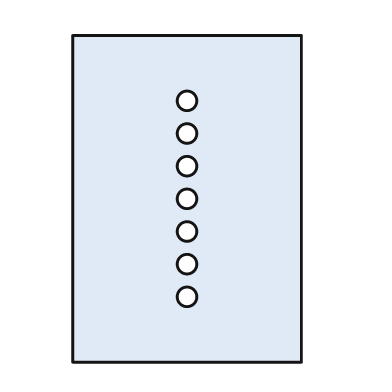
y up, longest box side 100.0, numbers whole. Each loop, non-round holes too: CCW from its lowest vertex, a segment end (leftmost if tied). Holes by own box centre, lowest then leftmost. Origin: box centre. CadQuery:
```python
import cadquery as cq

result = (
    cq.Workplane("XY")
    .moveTo(-35.0, -50.0)
    .lineTo(35.0, -50.0)
    .lineTo(35.0, 50.0)
    .lineTo(-35.0, 50.0)
    .close()
    .moveTo(0.0, -30.0)
    .circle(3.0)
    .moveTo(0.0, -20.0)
    .circle(3.0)
    .moveTo(0.0, -10.0)
    .circle(3.0)
    .moveTo(0.0, 0.0)
    .circle(3.0)
    .moveTo(0.0, 10.0)
    .circle(3.0)
    .moveTo(0.0, 20.0)
    .circle(3.0)
    .moveTo(0.0, 30.0)
    .circle(3.0)
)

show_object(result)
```